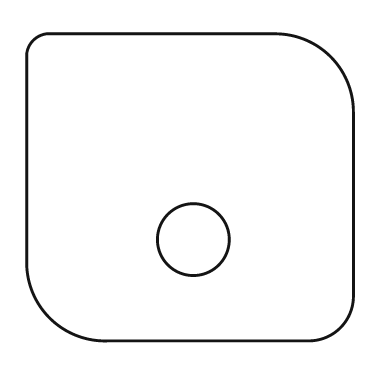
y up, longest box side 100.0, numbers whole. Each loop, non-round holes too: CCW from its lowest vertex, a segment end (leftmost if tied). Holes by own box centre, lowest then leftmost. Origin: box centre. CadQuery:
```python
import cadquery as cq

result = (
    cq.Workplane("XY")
    .moveTo(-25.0, -47.0)
    .lineTo(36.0, -47.0)
    .threePointArc((46.0, -43.0), (50.0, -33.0))
    .lineTo(50.0, 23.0)
    .threePointArc((43.0, 40.0), (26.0, 47.0))
    .lineTo(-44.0, 47.0)
    .threePointArc((-48.0, 45.0), (-50.0, 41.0))
    .lineTo(-50.0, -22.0)
    .threePointArc((-43.0, -40.0), (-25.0, -47.0))
    .close()
    .moveTo(1.0, -16.0)
    .circle(11.0)
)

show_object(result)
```